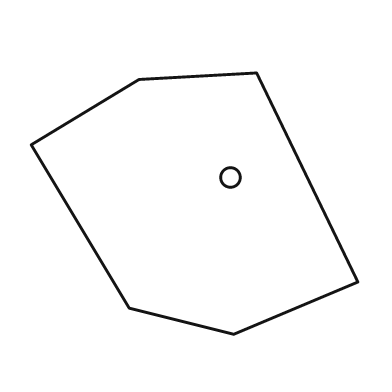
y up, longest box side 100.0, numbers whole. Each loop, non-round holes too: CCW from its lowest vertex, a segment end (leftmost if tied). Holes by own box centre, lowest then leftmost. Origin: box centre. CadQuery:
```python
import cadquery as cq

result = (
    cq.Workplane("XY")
    .moveTo(12.0, -40.0)
    .lineTo(50.0, -24.0)
    .lineTo(19.0, 40.0)
    .lineTo(-17.0, 38.0)
    .lineTo(-50.0, 18.0)
    .lineTo(-20.0, -32.0)
    .close()
    .moveTo(11.0, 8.0)
    .circle(3.0)
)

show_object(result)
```